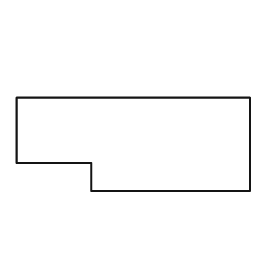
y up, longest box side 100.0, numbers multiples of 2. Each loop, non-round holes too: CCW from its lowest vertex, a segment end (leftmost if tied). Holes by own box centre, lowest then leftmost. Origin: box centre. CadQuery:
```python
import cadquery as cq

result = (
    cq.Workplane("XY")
    .moveTo(-18.0, -20.0)
    .lineTo(50.0, -20.0)
    .lineTo(50.0, 20.0)
    .lineTo(-50.0, 20.0)
    .lineTo(-50.0, -8.0)
    .lineTo(-18.0, -8.0)
    .close()
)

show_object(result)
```